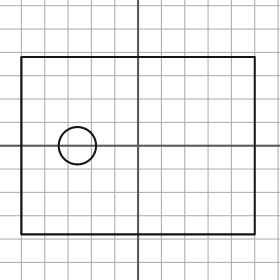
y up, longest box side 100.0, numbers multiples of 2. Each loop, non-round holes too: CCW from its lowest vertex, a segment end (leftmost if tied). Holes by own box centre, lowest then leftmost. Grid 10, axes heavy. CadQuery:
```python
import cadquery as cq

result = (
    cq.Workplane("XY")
    .moveTo(-50.0, -38.0)
    .lineTo(50.0, -38.0)
    .lineTo(50.0, 38.0)
    .lineTo(-50.0, 38.0)
    .close()
    .moveTo(-26.0, 0.0)
    .circle(8.0)
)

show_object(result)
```